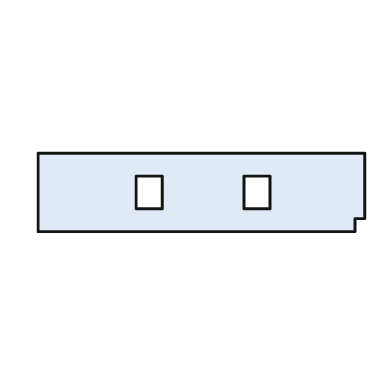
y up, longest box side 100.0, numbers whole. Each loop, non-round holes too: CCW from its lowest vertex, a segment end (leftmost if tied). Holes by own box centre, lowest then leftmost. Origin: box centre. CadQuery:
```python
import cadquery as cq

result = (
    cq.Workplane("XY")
    .moveTo(-50.0, -12.0)
    .lineTo(47.0, -12.0)
    .lineTo(47.0, -8.0)
    .lineTo(50.0, -8.0)
    .lineTo(50.0, 12.0)
    .lineTo(-50.0, 12.0)
    .close()
    .moveTo(-20.0, -5.0)
    .lineTo(-12.0, -5.0)
    .lineTo(-12.0, 5.0)
    .lineTo(-20.0, 5.0)
    .close()
    .moveTo(13.0, -5.0)
    .lineTo(21.0, -5.0)
    .lineTo(21.0, 5.0)
    .lineTo(13.0, 5.0)
    .close()
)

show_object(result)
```